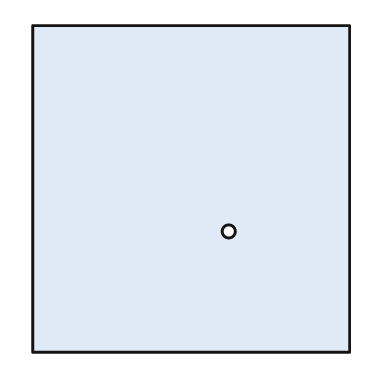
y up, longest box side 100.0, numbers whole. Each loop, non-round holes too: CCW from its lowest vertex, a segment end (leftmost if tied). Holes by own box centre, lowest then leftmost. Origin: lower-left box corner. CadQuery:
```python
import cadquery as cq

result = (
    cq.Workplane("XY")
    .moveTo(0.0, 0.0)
    .lineTo(97.0, 0.0)
    .lineTo(97.0, 100.0)
    .lineTo(0.0, 100.0)
    .close()
    .moveTo(60.0, 37.0)
    .circle(2.0)
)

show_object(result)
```